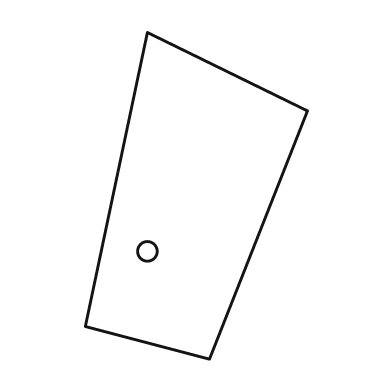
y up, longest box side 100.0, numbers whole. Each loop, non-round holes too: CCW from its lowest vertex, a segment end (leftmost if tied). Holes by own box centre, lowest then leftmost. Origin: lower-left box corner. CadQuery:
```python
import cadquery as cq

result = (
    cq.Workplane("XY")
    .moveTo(38.0, 0.0)
    .lineTo(68.0, 76.0)
    .lineTo(19.0, 100.0)
    .lineTo(0.0, 10.0)
    .close()
    .moveTo(19.0, 33.0)
    .circle(3.0)
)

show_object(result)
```